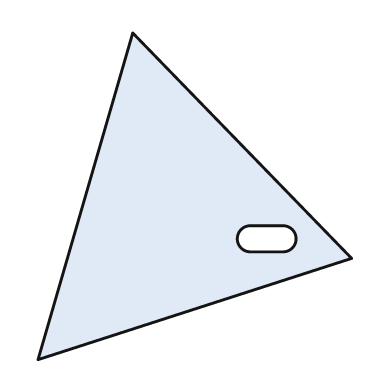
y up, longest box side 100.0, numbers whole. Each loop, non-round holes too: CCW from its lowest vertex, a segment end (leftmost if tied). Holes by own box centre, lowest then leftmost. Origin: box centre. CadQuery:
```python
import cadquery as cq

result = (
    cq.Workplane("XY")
    .moveTo(-48.0, -50.0)
    .lineTo(48.0, -19.0)
    .lineTo(-19.0, 50.0)
    .close()
    .moveTo(17.0, -17.0)
    .lineTo(27.0, -17.0)
    .threePointArc((31.0, -13.0), (27.0, -9.0))
    .lineTo(17.0, -9.0)
    .threePointArc((13.0, -13.0), (17.0, -17.0))
    .close()
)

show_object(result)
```